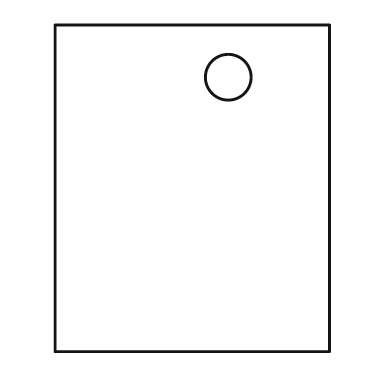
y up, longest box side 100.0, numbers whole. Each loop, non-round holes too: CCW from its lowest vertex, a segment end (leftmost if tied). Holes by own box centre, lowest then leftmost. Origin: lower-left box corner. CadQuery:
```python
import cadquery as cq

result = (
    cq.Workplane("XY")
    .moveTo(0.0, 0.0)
    .lineTo(84.0, 0.0)
    .lineTo(84.0, 100.0)
    .lineTo(0.0, 100.0)
    .close()
    .moveTo(53.0, 84.0)
    .circle(7.0)
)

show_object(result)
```